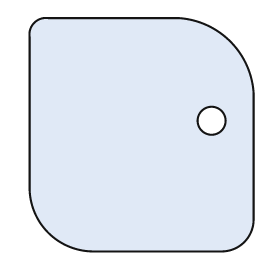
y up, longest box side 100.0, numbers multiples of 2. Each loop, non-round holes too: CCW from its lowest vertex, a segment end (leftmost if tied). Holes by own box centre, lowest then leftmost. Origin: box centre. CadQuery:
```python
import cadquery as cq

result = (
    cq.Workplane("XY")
    .moveTo(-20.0, -50.0)
    .lineTo(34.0, -50.0)
    .threePointArc((44.0, -46.0), (48.0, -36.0))
    .lineTo(48.0, 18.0)
    .threePointArc((38.0, 40.0), (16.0, 50.0))
    .lineTo(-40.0, 50.0)
    .threePointArc((-46.0, 48.0), (-48.0, 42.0))
    .lineTo(-48.0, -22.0)
    .threePointArc((-40.0, -42.0), (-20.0, -50.0))
    .close()
    .moveTo(30.0, 6.0)
    .circle(6.0)
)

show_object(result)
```